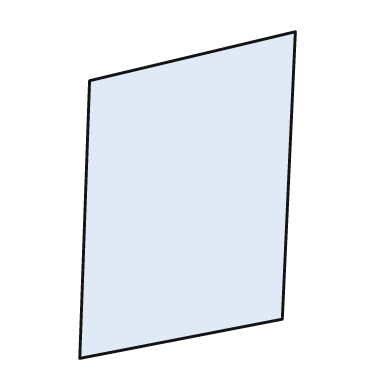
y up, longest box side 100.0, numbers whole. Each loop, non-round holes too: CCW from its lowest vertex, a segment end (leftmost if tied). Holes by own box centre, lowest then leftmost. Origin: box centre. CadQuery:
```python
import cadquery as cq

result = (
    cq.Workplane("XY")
    .moveTo(-33.0, -50.0)
    .lineTo(29.0, -38.0)
    .lineTo(33.0, 50.0)
    .lineTo(-30.0, 35.0)
    .close()
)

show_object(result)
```